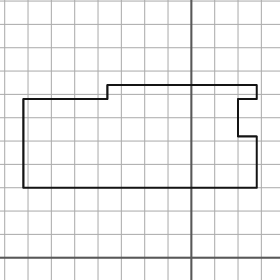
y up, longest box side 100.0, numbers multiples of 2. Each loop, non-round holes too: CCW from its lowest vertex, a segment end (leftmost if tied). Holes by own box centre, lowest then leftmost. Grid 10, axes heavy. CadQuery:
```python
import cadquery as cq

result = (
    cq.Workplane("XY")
    .moveTo(-72.0, 30.0)
    .lineTo(28.0, 30.0)
    .lineTo(28.0, 52.0)
    .lineTo(20.0, 52.0)
    .lineTo(20.0, 68.0)
    .lineTo(28.0, 68.0)
    .lineTo(28.0, 74.0)
    .lineTo(-36.0, 74.0)
    .lineTo(-36.0, 68.0)
    .lineTo(-72.0, 68.0)
    .close()
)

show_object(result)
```